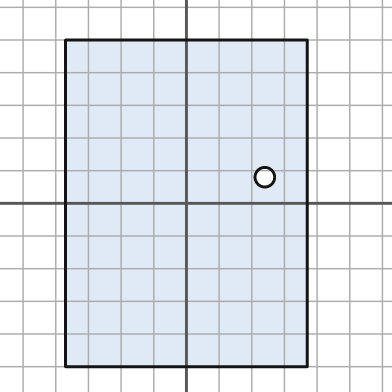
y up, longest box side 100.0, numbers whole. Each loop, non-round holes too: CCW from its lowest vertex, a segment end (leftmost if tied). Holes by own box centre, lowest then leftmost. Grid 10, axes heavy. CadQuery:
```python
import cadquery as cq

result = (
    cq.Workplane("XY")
    .moveTo(-37.0, -50.0)
    .lineTo(37.0, -50.0)
    .lineTo(37.0, 50.0)
    .lineTo(-37.0, 50.0)
    .close()
    .moveTo(24.0, 8.0)
    .circle(3.0)
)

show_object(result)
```